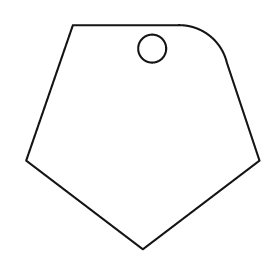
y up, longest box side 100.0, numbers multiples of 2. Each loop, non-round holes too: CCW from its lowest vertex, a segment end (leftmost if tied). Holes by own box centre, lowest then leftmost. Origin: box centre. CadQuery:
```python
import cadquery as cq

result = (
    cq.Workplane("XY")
    .moveTo(0.0, -48.0)
    .lineTo(50.0, -10.0)
    .lineTo(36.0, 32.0)
    .threePointArc((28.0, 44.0), (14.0, 48.0))
    .lineTo(-30.0, 48.0)
    .lineTo(-50.0, -10.0)
    .close()
    .moveTo(4.0, 38.0)
    .circle(6.0)
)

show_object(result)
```